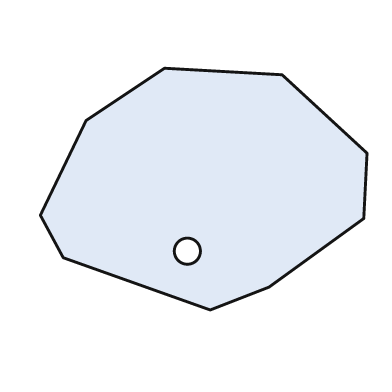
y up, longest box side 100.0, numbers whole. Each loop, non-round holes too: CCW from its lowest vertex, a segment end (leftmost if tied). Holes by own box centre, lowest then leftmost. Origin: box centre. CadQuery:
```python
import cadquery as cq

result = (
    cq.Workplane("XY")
    .moveTo(2.0, -37.0)
    .lineTo(20.0, -30.0)
    .lineTo(49.0, -9.0)
    .lineTo(50.0, 11.0)
    .lineTo(24.0, 35.0)
    .lineTo(-12.0, 37.0)
    .lineTo(-36.0, 21.0)
    .lineTo(-50.0, -8.0)
    .lineTo(-43.0, -21.0)
    .close()
    .moveTo(-5.0, -19.0)
    .circle(4.0)
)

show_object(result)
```